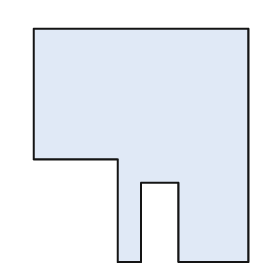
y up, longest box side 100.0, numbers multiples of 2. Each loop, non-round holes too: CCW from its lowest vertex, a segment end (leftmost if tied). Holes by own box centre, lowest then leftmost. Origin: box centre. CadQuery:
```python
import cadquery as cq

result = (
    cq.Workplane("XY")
    .moveTo(-10.0, -50.0)
    .lineTo(0.0, -50.0)
    .lineTo(0.0, -16.0)
    .lineTo(16.0, -16.0)
    .lineTo(16.0, -50.0)
    .lineTo(46.0, -50.0)
    .lineTo(46.0, 50.0)
    .lineTo(-46.0, 50.0)
    .lineTo(-46.0, -6.0)
    .lineTo(-10.0, -6.0)
    .close()
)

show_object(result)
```